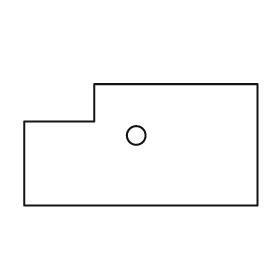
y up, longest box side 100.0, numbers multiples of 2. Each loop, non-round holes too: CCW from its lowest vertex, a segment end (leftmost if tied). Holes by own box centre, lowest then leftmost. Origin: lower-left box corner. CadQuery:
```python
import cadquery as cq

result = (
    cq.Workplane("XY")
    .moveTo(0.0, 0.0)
    .lineTo(100.0, 0.0)
    .lineTo(100.0, 52.0)
    .lineTo(30.0, 52.0)
    .lineTo(30.0, 36.0)
    .lineTo(0.0, 36.0)
    .close()
    .moveTo(48.0, 30.0)
    .circle(4.0)
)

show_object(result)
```